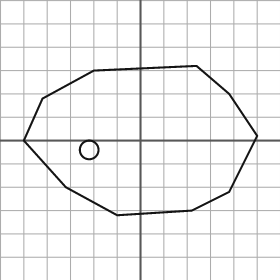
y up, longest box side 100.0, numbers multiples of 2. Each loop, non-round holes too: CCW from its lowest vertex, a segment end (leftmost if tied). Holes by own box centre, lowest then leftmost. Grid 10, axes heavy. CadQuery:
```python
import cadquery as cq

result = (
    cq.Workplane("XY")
    .moveTo(-10.0, -32.0)
    .lineTo(22.0, -30.0)
    .lineTo(38.0, -22.0)
    .lineTo(50.0, 2.0)
    .lineTo(38.0, 20.0)
    .lineTo(24.0, 32.0)
    .lineTo(-20.0, 30.0)
    .lineTo(-42.0, 18.0)
    .lineTo(-50.0, 0.0)
    .lineTo(-32.0, -20.0)
    .close()
    .moveTo(-22.0, -4.0)
    .circle(4.0)
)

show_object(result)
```